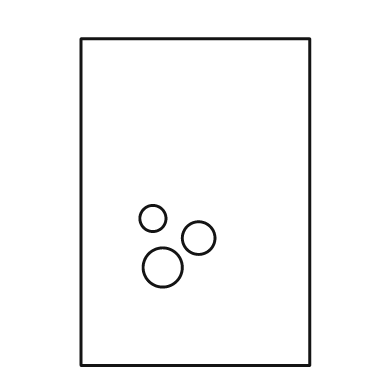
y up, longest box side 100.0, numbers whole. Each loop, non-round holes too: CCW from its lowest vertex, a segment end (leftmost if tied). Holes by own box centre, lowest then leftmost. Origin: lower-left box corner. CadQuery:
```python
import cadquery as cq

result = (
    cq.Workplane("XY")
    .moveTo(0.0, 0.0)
    .lineTo(70.0, 0.0)
    .lineTo(70.0, 100.0)
    .lineTo(0.0, 100.0)
    .close()
    .moveTo(25.0, 30.0)
    .circle(6.0)
    .moveTo(36.0, 39.0)
    .circle(5.0)
    .moveTo(22.0, 45.0)
    .circle(4.0)
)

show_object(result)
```